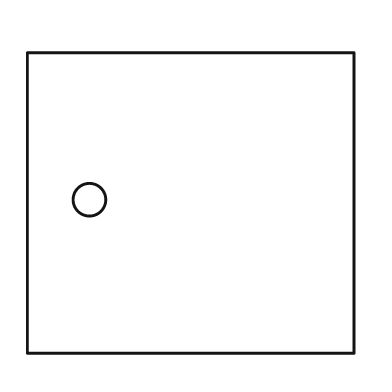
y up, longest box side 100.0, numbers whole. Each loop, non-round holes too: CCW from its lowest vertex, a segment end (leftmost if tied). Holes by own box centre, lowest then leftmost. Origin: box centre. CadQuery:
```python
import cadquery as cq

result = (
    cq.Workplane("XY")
    .moveTo(-50.0, -46.0)
    .lineTo(50.0, -46.0)
    .lineTo(50.0, 46.0)
    .lineTo(-50.0, 46.0)
    .close()
    .moveTo(-31.0, 1.0)
    .circle(5.0)
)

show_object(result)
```